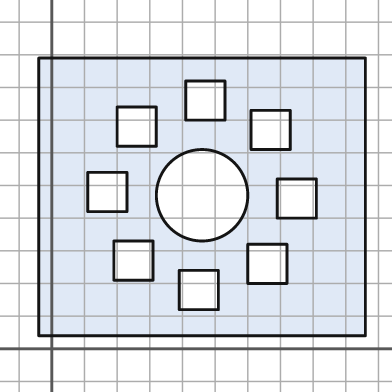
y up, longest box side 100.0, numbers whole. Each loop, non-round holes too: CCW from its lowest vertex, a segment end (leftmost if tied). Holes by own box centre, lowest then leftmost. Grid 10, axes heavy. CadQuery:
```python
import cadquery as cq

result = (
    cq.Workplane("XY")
    .moveTo(-4.0, 4.0)
    .lineTo(96.0, 4.0)
    .lineTo(96.0, 89.0)
    .lineTo(-4.0, 89.0)
    .close()
    .moveTo(39.0, 12.0)
    .lineTo(51.0, 12.0)
    .lineTo(51.0, 24.0)
    .lineTo(39.0, 24.0)
    .close()
    .moveTo(60.0, 20.0)
    .lineTo(72.0, 20.0)
    .lineTo(72.0, 32.0)
    .lineTo(60.0, 32.0)
    .close()
    .moveTo(19.0, 21.0)
    .lineTo(31.0, 21.0)
    .lineTo(31.0, 33.0)
    .lineTo(19.0, 33.0)
    .close()
    .moveTo(69.0, 40.0)
    .lineTo(81.0, 40.0)
    .lineTo(81.0, 52.0)
    .lineTo(69.0, 52.0)
    .close()
    .moveTo(46.0, 47.0)
    .circle(14.0)
    .moveTo(11.0, 42.0)
    .lineTo(23.0, 42.0)
    .lineTo(23.0, 54.0)
    .lineTo(11.0, 54.0)
    .close()
    .moveTo(61.0, 61.0)
    .lineTo(73.0, 61.0)
    .lineTo(73.0, 73.0)
    .lineTo(61.0, 73.0)
    .close()
    .moveTo(20.0, 62.0)
    .lineTo(32.0, 62.0)
    .lineTo(32.0, 74.0)
    .lineTo(20.0, 74.0)
    .close()
    .moveTo(41.0, 70.0)
    .lineTo(53.0, 70.0)
    .lineTo(53.0, 82.0)
    .lineTo(41.0, 82.0)
    .close()
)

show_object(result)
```